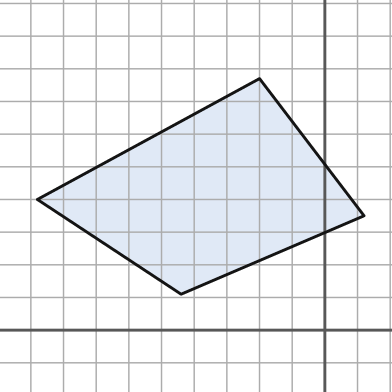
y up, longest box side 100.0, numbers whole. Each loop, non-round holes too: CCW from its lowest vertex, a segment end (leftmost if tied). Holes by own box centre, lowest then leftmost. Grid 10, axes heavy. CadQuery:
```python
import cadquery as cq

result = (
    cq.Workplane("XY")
    .moveTo(-44.0, 11.0)
    .lineTo(12.0, 35.0)
    .lineTo(-20.0, 77.0)
    .lineTo(-88.0, 40.0)
    .close()
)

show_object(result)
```